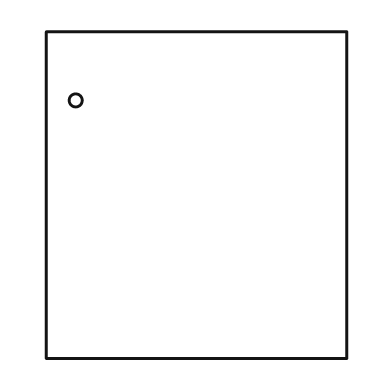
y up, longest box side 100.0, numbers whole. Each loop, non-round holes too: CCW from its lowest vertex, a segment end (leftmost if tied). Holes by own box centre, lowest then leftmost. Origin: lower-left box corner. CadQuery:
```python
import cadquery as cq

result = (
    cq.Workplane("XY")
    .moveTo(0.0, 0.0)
    .lineTo(92.0, 0.0)
    .lineTo(92.0, 100.0)
    .lineTo(0.0, 100.0)
    .close()
    .moveTo(9.0, 79.0)
    .circle(2.0)
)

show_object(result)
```